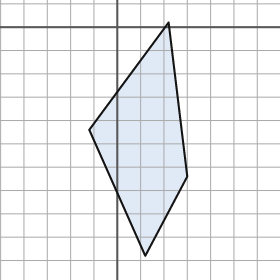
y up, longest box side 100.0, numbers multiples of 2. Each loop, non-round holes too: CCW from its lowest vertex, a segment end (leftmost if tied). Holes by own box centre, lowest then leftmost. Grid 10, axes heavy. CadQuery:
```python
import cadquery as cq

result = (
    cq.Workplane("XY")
    .moveTo(12.0, -98.0)
    .lineTo(30.0, -64.0)
    .lineTo(22.0, 2.0)
    .lineTo(-12.0, -44.0)
    .close()
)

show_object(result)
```